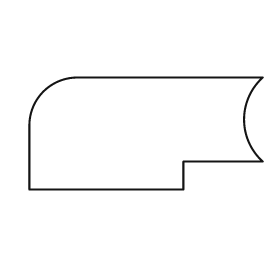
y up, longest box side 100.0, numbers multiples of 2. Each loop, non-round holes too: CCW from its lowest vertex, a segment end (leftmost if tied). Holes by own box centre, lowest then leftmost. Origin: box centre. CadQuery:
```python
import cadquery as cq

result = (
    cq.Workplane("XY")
    .moveTo(-50.0, -24.0)
    .lineTo(16.0, -24.0)
    .lineTo(16.0, -12.0)
    .lineTo(50.0, -12.0)
    .threePointArc((42.0, 6.0), (50.0, 24.0))
    .lineTo(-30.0, 24.0)
    .threePointArc((-44.0, 18.0), (-50.0, 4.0))
    .close()
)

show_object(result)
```